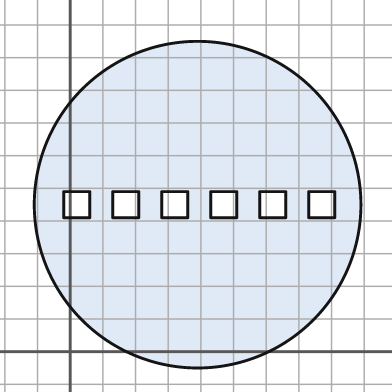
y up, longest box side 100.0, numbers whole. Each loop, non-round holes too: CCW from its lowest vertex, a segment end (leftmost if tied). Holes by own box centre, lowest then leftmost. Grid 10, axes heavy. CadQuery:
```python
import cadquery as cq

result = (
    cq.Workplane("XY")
    .moveTo(39.0, 45.0)
    .circle(50.0)
    .moveTo(-2.0, 41.0)
    .lineTo(6.0, 41.0)
    .lineTo(6.0, 49.0)
    .lineTo(-2.0, 49.0)
    .close()
    .moveTo(13.0, 41.0)
    .lineTo(21.0, 41.0)
    .lineTo(21.0, 49.0)
    .lineTo(13.0, 49.0)
    .close()
    .moveTo(28.0, 41.0)
    .lineTo(36.0, 41.0)
    .lineTo(36.0, 49.0)
    .lineTo(28.0, 49.0)
    .close()
    .moveTo(43.0, 41.0)
    .lineTo(51.0, 41.0)
    .lineTo(51.0, 49.0)
    .lineTo(43.0, 49.0)
    .close()
    .moveTo(58.0, 41.0)
    .lineTo(66.0, 41.0)
    .lineTo(66.0, 49.0)
    .lineTo(58.0, 49.0)
    .close()
    .moveTo(73.0, 41.0)
    .lineTo(81.0, 41.0)
    .lineTo(81.0, 49.0)
    .lineTo(73.0, 49.0)
    .close()
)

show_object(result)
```